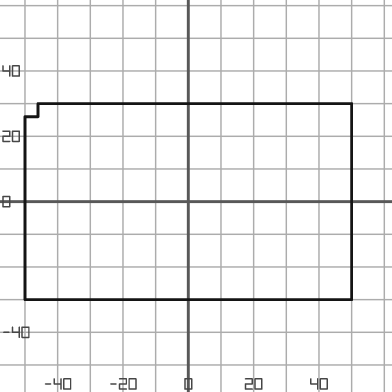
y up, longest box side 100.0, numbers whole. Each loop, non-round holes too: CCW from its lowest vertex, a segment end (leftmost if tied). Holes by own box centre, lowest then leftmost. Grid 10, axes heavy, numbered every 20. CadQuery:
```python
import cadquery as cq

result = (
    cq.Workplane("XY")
    .moveTo(-50.0, -30.0)
    .lineTo(50.0, -30.0)
    .lineTo(50.0, 30.0)
    .lineTo(-46.0, 30.0)
    .lineTo(-46.0, 26.0)
    .lineTo(-50.0, 26.0)
    .close()
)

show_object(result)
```